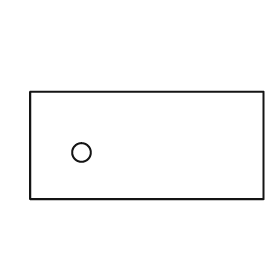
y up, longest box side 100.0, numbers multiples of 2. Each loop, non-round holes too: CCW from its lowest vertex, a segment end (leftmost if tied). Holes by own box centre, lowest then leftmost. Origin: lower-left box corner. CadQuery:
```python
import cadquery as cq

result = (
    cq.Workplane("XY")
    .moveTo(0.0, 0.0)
    .lineTo(100.0, 0.0)
    .lineTo(100.0, 46.0)
    .lineTo(0.0, 46.0)
    .close()
    .moveTo(22.0, 20.0)
    .circle(4.0)
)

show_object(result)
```